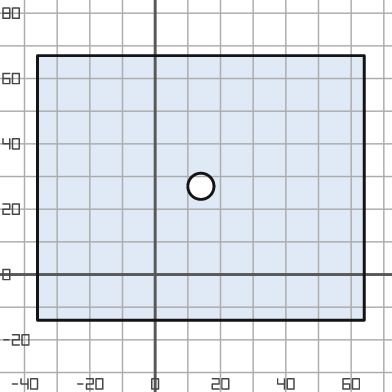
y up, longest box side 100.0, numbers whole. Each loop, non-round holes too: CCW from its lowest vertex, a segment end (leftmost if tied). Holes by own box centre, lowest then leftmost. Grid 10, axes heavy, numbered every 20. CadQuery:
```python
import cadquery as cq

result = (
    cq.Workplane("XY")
    .moveTo(-36.0, -14.0)
    .lineTo(64.0, -14.0)
    .lineTo(64.0, 67.0)
    .lineTo(-36.0, 67.0)
    .close()
    .moveTo(14.0, 27.0)
    .circle(4.0)
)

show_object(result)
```